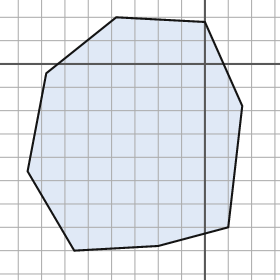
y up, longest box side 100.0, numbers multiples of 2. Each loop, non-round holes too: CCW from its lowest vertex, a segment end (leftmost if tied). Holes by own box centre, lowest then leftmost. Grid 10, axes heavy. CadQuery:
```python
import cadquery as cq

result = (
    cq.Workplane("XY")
    .moveTo(-56.0, -80.0)
    .lineTo(-20.0, -78.0)
    .lineTo(10.0, -70.0)
    .lineTo(16.0, -18.0)
    .lineTo(0.0, 18.0)
    .lineTo(-38.0, 20.0)
    .lineTo(-68.0, -4.0)
    .lineTo(-76.0, -46.0)
    .close()
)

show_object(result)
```